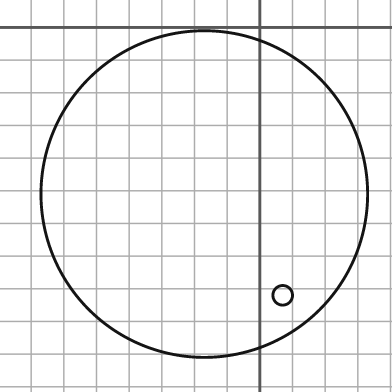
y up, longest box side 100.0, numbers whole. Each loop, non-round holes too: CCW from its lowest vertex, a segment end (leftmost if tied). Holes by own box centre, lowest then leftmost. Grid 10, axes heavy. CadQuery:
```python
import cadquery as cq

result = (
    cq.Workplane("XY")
    .moveTo(-17.0, -51.0)
    .circle(50.0)
    .moveTo(7.0, -82.0)
    .circle(3.0)
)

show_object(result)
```